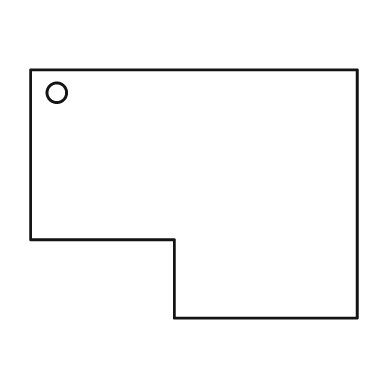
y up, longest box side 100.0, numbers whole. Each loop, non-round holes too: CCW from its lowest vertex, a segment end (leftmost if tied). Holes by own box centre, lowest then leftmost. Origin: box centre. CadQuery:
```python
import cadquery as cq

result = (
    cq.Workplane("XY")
    .moveTo(-6.0, -38.0)
    .lineTo(50.0, -38.0)
    .lineTo(50.0, 38.0)
    .lineTo(-50.0, 38.0)
    .lineTo(-50.0, -14.0)
    .lineTo(-6.0, -14.0)
    .close()
    .moveTo(-42.0, 31.0)
    .circle(3.0)
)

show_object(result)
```